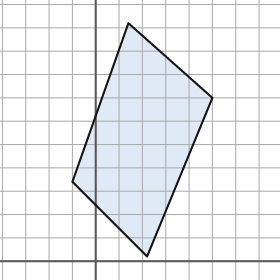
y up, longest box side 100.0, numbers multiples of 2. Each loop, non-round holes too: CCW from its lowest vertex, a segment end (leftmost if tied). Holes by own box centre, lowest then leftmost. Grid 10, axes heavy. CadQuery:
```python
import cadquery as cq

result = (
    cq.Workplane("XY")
    .moveTo(22.0, 2.0)
    .lineTo(50.0, 70.0)
    .lineTo(14.0, 102.0)
    .lineTo(-10.0, 34.0)
    .close()
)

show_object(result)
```